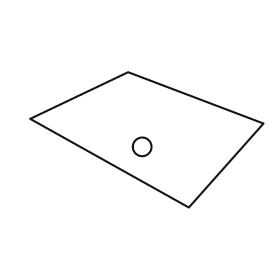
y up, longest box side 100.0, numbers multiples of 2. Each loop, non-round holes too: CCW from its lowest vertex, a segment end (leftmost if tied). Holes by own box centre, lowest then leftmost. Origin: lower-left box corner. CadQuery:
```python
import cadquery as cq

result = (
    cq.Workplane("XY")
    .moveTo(68.0, 0.0)
    .lineTo(100.0, 36.0)
    .lineTo(42.0, 58.0)
    .lineTo(0.0, 38.0)
    .close()
    .moveTo(48.0, 26.0)
    .circle(4.0)
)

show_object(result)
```